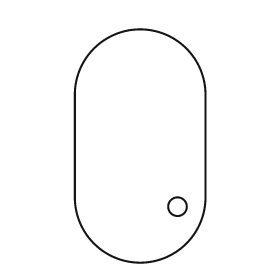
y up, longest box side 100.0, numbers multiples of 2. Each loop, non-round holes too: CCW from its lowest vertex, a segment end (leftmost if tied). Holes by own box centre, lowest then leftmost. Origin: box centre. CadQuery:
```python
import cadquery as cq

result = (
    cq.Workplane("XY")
    .moveTo(-28.0, -22.0)
    .threePointArc((0.0, -50.0), (28.0, -22.0))
    .lineTo(28.0, 22.0)
    .threePointArc((0.0, 50.0), (-28.0, 22.0))
    .close()
    .moveTo(16.0, -26.0)
    .circle(4.0)
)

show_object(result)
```